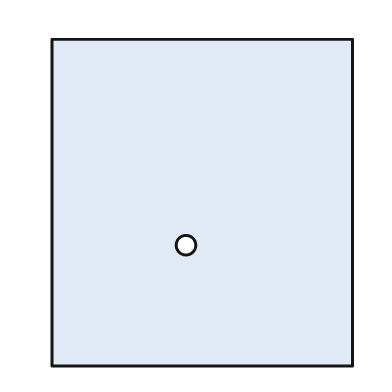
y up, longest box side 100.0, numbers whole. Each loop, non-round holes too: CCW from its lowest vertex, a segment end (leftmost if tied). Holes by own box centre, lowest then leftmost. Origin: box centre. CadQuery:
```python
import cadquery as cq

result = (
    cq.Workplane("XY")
    .moveTo(-46.0, -50.0)
    .lineTo(46.0, -50.0)
    .lineTo(46.0, 50.0)
    .lineTo(-46.0, 50.0)
    .close()
    .moveTo(-5.0, -13.0)
    .circle(3.0)
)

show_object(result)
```